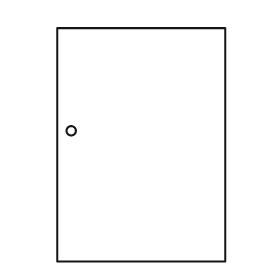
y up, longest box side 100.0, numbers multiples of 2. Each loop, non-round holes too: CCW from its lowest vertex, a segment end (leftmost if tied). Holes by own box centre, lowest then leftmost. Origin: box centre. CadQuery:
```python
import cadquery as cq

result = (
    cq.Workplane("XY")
    .moveTo(-36.0, -50.0)
    .lineTo(36.0, -50.0)
    .lineTo(36.0, 50.0)
    .lineTo(-36.0, 50.0)
    .close()
    .moveTo(-30.0, 6.0)
    .circle(2.0)
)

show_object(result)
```